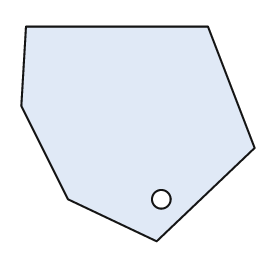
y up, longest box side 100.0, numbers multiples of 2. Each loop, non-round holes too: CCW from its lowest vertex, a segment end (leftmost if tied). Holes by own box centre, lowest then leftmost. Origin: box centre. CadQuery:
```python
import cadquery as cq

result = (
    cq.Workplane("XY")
    .moveTo(8.0, -46.0)
    .lineTo(50.0, -6.0)
    .lineTo(30.0, 46.0)
    .lineTo(-48.0, 46.0)
    .lineTo(-50.0, 12.0)
    .lineTo(-30.0, -28.0)
    .close()
    .moveTo(10.0, -28.0)
    .circle(4.0)
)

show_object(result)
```